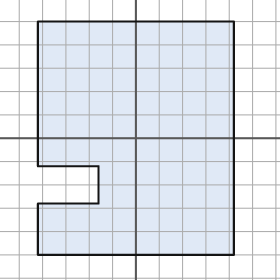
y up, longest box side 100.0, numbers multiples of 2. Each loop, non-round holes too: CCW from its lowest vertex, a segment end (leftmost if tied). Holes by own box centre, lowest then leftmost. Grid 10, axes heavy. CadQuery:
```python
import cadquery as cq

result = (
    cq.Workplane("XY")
    .moveTo(-42.0, -50.0)
    .lineTo(42.0, -50.0)
    .lineTo(42.0, 50.0)
    .lineTo(-42.0, 50.0)
    .lineTo(-42.0, -12.0)
    .lineTo(-16.0, -12.0)
    .lineTo(-16.0, -28.0)
    .lineTo(-42.0, -28.0)
    .close()
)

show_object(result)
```